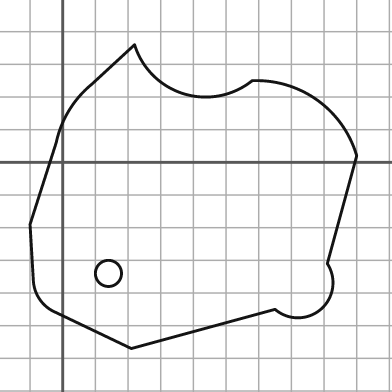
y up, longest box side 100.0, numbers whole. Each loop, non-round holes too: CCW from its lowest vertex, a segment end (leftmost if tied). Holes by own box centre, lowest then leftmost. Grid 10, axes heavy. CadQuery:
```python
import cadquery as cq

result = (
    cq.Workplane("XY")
    .moveTo(21.0, -57.0)
    .lineTo(65.0, -45.0)
    .threePointArc((79.0, -45.0), (81.0, -31.0))
    .lineTo(90.0, 2.0)
    .threePointArc((78.0, 19.0), (58.0, 25.0))
    .threePointArc((37.0, 21.0), (22.0, 36.0))
    .lineTo(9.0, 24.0)
    .threePointArc((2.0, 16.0), (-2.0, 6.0))
    .lineTo(-10.0, -19.0)
    .lineTo(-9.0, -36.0)
    .threePointArc((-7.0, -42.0), (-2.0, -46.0))
    .close()
    .moveTo(14.0, -34.0)
    .circle(4.0)
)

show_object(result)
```